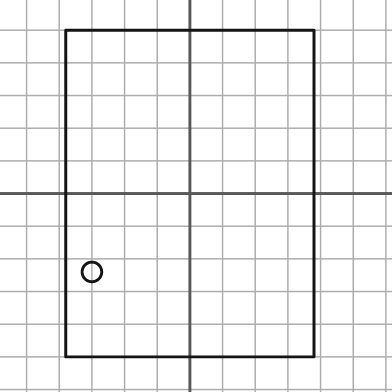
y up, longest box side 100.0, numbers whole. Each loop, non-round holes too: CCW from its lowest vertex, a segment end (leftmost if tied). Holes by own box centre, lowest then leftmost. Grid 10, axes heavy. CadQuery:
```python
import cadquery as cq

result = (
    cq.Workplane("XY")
    .moveTo(-38.0, -50.0)
    .lineTo(38.0, -50.0)
    .lineTo(38.0, 50.0)
    .lineTo(-38.0, 50.0)
    .close()
    .moveTo(-30.0, -24.0)
    .circle(3.0)
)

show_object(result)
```